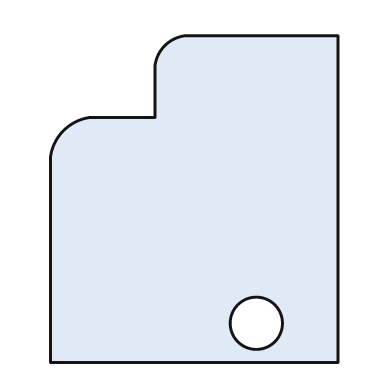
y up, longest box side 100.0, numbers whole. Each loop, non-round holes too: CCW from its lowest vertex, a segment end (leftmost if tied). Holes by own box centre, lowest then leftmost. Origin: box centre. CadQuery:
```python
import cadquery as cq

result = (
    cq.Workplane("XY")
    .moveTo(-44.0, -50.0)
    .lineTo(44.0, -50.0)
    .lineTo(44.0, 50.0)
    .lineTo(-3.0, 50.0)
    .threePointArc((-9.0, 47.0), (-12.0, 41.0))
    .lineTo(-12.0, 25.0)
    .lineTo(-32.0, 25.0)
    .threePointArc((-40.0, 21.0), (-44.0, 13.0))
    .close()
    .moveTo(19.0, -38.0)
    .circle(8.0)
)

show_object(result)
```